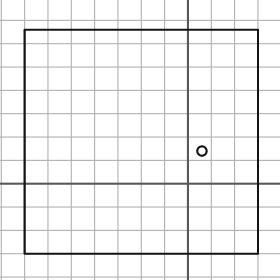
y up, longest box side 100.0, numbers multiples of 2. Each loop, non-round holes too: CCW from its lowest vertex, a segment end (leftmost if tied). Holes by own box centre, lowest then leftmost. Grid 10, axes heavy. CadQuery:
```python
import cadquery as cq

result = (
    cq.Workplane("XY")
    .moveTo(-70.0, -30.0)
    .lineTo(30.0, -30.0)
    .lineTo(30.0, 66.0)
    .lineTo(-70.0, 66.0)
    .close()
    .moveTo(6.0, 14.0)
    .circle(2.0)
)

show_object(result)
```